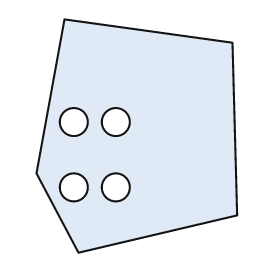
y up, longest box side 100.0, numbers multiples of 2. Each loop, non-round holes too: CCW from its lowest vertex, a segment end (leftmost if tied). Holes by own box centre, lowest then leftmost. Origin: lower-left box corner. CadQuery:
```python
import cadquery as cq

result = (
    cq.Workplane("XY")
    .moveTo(18.0, 0.0)
    .lineTo(86.0, 16.0)
    .lineTo(84.0, 90.0)
    .lineTo(12.0, 100.0)
    .lineTo(0.0, 34.0)
    .close()
    .moveTo(16.0, 28.0)
    .circle(6.0)
    .moveTo(34.0, 28.0)
    .circle(6.0)
    .moveTo(16.0, 56.0)
    .circle(6.0)
    .moveTo(34.0, 56.0)
    .circle(6.0)
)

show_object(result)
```